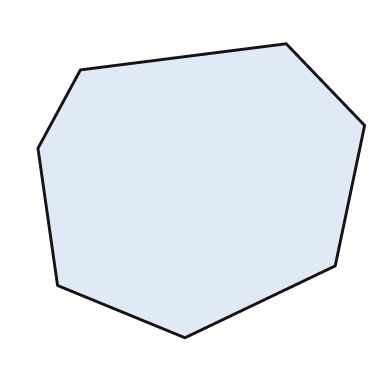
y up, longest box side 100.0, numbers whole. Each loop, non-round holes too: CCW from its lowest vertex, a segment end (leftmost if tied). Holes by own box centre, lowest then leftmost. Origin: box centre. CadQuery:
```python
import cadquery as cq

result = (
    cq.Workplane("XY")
    .moveTo(-5.0, -45.0)
    .lineTo(41.0, -23.0)
    .lineTo(50.0, 20.0)
    .lineTo(26.0, 45.0)
    .lineTo(-37.0, 37.0)
    .lineTo(-50.0, 13.0)
    .lineTo(-44.0, -29.0)
    .close()
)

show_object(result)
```